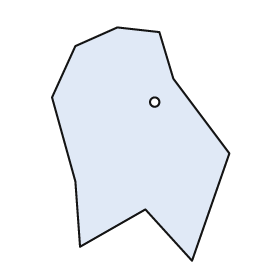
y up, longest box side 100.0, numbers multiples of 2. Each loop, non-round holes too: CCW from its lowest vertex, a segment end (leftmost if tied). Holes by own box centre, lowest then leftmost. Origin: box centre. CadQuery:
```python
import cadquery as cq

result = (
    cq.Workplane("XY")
    .moveTo(22.0, -50.0)
    .lineTo(38.0, -4.0)
    .lineTo(14.0, 28.0)
    .lineTo(8.0, 48.0)
    .lineTo(-10.0, 50.0)
    .lineTo(-28.0, 42.0)
    .lineTo(-38.0, 20.0)
    .lineTo(-28.0, -16.0)
    .lineTo(-26.0, -44.0)
    .lineTo(2.0, -28.0)
    .close()
    .moveTo(6.0, 18.0)
    .circle(2.0)
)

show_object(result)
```